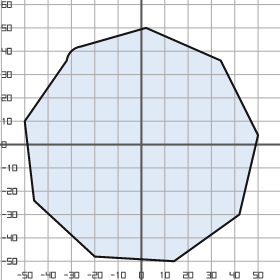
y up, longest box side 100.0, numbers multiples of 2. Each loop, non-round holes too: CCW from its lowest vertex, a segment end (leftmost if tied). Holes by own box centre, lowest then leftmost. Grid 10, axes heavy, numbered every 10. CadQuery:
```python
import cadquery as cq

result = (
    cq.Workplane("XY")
    .moveTo(14.0, -50.0)
    .lineTo(42.0, -30.0)
    .lineTo(50.0, 4.0)
    .lineTo(34.0, 36.0)
    .lineTo(2.0, 50.0)
    .lineTo(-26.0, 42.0)
    .threePointArc((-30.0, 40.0), (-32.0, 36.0))
    .lineTo(-50.0, 10.0)
    .lineTo(-46.0, -24.0)
    .lineTo(-20.0, -48.0)
    .close()
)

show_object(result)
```